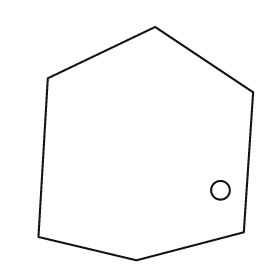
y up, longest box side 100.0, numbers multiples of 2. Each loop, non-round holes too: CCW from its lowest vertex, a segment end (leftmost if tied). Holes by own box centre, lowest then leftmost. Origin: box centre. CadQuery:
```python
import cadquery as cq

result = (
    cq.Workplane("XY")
    .moveTo(-4.0, -50.0)
    .lineTo(42.0, -38.0)
    .lineTo(46.0, 22.0)
    .lineTo(4.0, 50.0)
    .lineTo(-42.0, 28.0)
    .lineTo(-46.0, -40.0)
    .close()
    .moveTo(32.0, -20.0)
    .circle(4.0)
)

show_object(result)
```